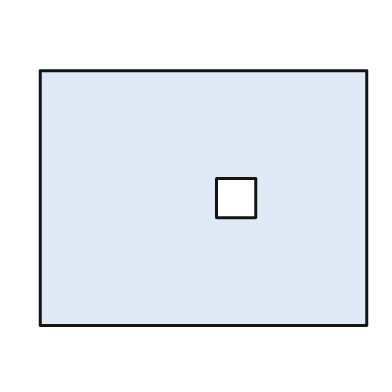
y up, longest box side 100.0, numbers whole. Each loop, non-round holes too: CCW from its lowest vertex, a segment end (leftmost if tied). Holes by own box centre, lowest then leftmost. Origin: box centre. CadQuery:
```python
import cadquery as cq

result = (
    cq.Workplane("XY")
    .moveTo(-50.0, -39.0)
    .lineTo(50.0, -39.0)
    .lineTo(50.0, 39.0)
    .lineTo(-50.0, 39.0)
    .close()
    .moveTo(4.0, -6.0)
    .lineTo(16.0, -6.0)
    .lineTo(16.0, 6.0)
    .lineTo(4.0, 6.0)
    .close()
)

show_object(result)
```